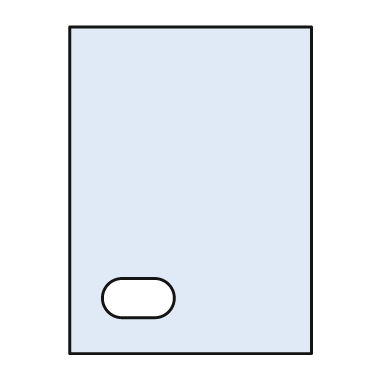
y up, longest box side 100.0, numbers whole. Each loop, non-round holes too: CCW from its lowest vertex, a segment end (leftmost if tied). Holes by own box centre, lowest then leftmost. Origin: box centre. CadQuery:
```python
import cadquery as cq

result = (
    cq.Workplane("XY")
    .moveTo(-37.0, -50.0)
    .lineTo(37.0, -50.0)
    .lineTo(37.0, 50.0)
    .lineTo(-37.0, 50.0)
    .close()
    .moveTo(-21.0, -39.0)
    .lineTo(-11.0, -39.0)
    .threePointArc((-5.0, -33.0), (-11.0, -27.0))
    .lineTo(-21.0, -27.0)
    .threePointArc((-27.0, -33.0), (-21.0, -39.0))
    .close()
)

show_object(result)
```